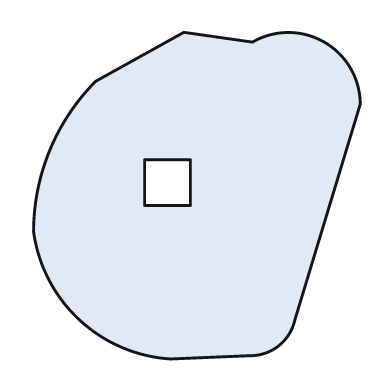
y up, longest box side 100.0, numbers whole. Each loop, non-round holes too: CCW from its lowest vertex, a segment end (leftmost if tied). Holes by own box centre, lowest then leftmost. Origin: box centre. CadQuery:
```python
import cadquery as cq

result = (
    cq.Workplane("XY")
    .moveTo(-8.0, -50.0)
    .lineTo(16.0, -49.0)
    .threePointArc((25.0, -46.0), (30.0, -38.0))
    .lineTo(50.0, 28.0)
    .threePointArc((39.0, 47.0), (17.0, 47.0))
    .lineTo(-4.0, 50.0)
    .lineTo(-31.0, 35.0)
    .threePointArc((-45.0, 14.0), (-50.0, -11.0))
    .threePointArc((-36.0, -38.0), (-8.0, -50.0))
    .close()
    .moveTo(-16.0, -3.0)
    .lineTo(-2.0, -3.0)
    .lineTo(-2.0, 11.0)
    .lineTo(-16.0, 11.0)
    .close()
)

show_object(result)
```